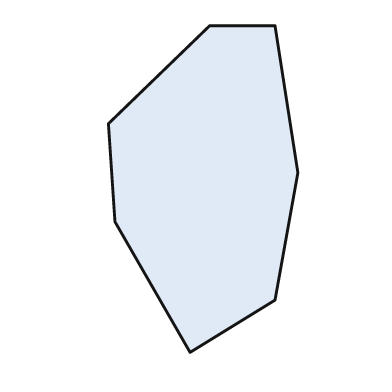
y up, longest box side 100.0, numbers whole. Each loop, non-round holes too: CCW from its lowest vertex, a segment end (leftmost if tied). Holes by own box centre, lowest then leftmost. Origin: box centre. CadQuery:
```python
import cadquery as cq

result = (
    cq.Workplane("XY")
    .moveTo(-4.0, -50.0)
    .lineTo(22.0, -34.0)
    .lineTo(29.0, 5.0)
    .lineTo(22.0, 50.0)
    .lineTo(2.0, 50.0)
    .lineTo(-29.0, 20.0)
    .lineTo(-27.0, -10.0)
    .close()
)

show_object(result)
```